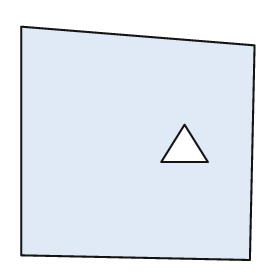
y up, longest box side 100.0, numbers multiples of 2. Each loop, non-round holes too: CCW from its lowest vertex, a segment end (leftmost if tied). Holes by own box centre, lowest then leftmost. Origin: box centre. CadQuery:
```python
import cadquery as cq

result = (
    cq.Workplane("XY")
    .moveTo(48.0, -50.0)
    .lineTo(50.0, 42.0)
    .lineTo(-50.0, 50.0)
    .lineTo(-50.0, -48.0)
    .close()
    .moveTo(10.0, -8.0)
    .lineTo(30.0, -8.0)
    .lineTo(20.0, 8.0)
    .close()
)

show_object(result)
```